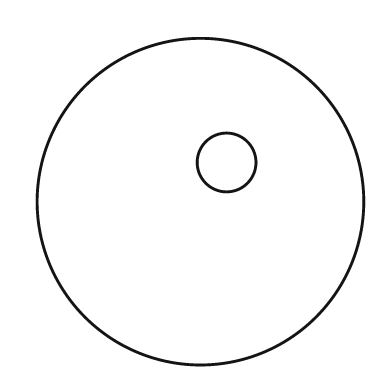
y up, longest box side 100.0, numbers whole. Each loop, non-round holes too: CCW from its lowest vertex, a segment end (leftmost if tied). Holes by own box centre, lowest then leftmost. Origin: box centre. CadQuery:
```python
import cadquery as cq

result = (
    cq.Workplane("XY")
    .moveTo(0.0, 0.0)
    .circle(50.0)
    .moveTo(8.0, 12.0)
    .circle(9.0)
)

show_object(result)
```